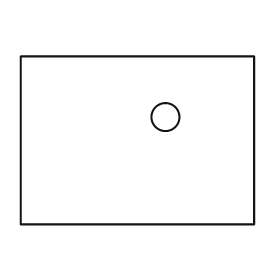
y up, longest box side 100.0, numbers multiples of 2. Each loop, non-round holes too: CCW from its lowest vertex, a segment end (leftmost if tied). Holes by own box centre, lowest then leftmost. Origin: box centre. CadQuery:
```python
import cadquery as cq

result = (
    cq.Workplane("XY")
    .moveTo(-50.0, -36.0)
    .lineTo(50.0, -36.0)
    .lineTo(50.0, 36.0)
    .lineTo(-50.0, 36.0)
    .close()
    .moveTo(12.0, 10.0)
    .circle(6.0)
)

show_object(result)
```